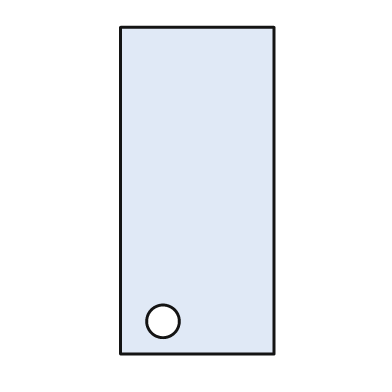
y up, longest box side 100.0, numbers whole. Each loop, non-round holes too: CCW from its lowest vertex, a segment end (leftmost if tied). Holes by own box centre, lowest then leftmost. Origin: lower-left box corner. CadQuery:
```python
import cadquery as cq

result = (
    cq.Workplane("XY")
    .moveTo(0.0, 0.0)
    .lineTo(47.0, 0.0)
    .lineTo(47.0, 100.0)
    .lineTo(0.0, 100.0)
    .close()
    .moveTo(13.0, 10.0)
    .circle(5.0)
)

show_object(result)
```